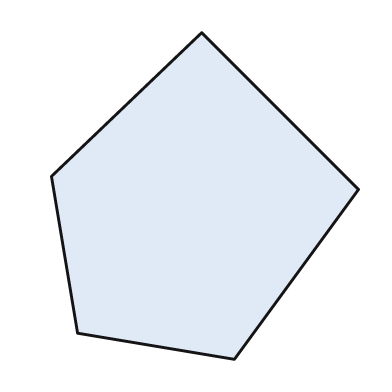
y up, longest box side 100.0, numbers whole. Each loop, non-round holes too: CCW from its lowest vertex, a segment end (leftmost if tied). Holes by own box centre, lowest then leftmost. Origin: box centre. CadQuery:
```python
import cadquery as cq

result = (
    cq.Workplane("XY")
    .moveTo(9.0, -50.0)
    .lineTo(47.0, 2.0)
    .lineTo(-1.0, 50.0)
    .lineTo(-47.0, 6.0)
    .lineTo(-39.0, -42.0)
    .close()
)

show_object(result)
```